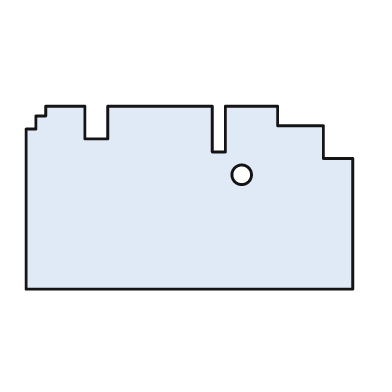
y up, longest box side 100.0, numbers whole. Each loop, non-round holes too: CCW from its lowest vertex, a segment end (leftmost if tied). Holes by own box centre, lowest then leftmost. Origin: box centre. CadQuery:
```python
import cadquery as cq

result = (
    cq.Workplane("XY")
    .moveTo(-50.0, -28.0)
    .lineTo(50.0, -28.0)
    .lineTo(50.0, 12.0)
    .lineTo(41.0, 12.0)
    .lineTo(41.0, 22.0)
    .lineTo(27.0, 22.0)
    .lineTo(27.0, 28.0)
    .lineTo(11.0, 28.0)
    .lineTo(11.0, 14.0)
    .lineTo(7.0, 14.0)
    .lineTo(7.0, 28.0)
    .lineTo(-25.0, 28.0)
    .lineTo(-25.0, 18.0)
    .lineTo(-32.0, 18.0)
    .lineTo(-32.0, 28.0)
    .lineTo(-44.0, 28.0)
    .lineTo(-44.0, 25.0)
    .lineTo(-47.0, 25.0)
    .lineTo(-47.0, 21.0)
    .lineTo(-50.0, 21.0)
    .close()
    .moveTo(16.0, 7.0)
    .circle(3.0)
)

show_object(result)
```